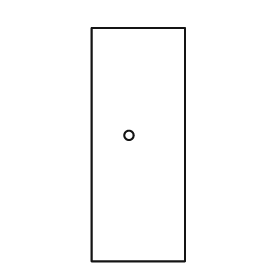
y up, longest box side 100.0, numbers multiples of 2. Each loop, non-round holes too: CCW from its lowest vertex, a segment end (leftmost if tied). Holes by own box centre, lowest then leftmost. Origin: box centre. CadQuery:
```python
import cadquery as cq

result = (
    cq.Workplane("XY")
    .moveTo(-20.0, -50.0)
    .lineTo(20.0, -50.0)
    .lineTo(20.0, 50.0)
    .lineTo(-20.0, 50.0)
    .close()
    .moveTo(-4.0, 4.0)
    .circle(2.0)
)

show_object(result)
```